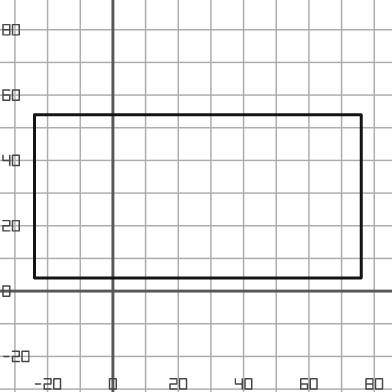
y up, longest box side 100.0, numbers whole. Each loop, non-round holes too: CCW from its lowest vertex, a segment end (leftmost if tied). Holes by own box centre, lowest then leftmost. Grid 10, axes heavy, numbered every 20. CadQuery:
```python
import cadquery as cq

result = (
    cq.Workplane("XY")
    .moveTo(-24.0, 4.0)
    .lineTo(76.0, 4.0)
    .lineTo(76.0, 54.0)
    .lineTo(-24.0, 54.0)
    .close()
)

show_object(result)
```